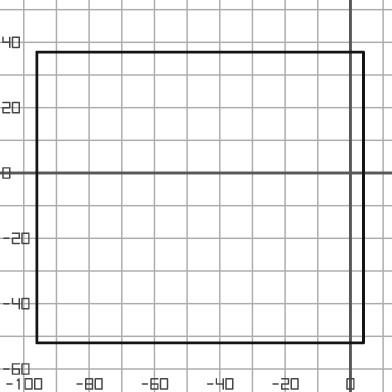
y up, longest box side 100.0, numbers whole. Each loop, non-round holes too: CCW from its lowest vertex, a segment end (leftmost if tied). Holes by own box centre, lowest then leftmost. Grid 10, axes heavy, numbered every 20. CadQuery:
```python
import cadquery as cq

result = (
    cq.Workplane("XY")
    .moveTo(-96.0, -52.0)
    .lineTo(4.0, -52.0)
    .lineTo(4.0, 37.0)
    .lineTo(-96.0, 37.0)
    .close()
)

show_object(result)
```